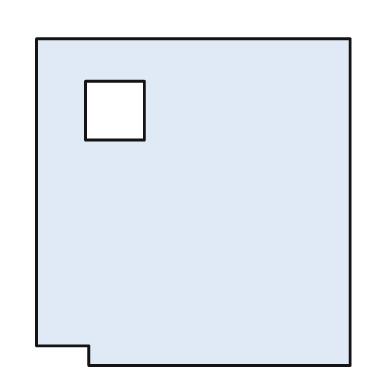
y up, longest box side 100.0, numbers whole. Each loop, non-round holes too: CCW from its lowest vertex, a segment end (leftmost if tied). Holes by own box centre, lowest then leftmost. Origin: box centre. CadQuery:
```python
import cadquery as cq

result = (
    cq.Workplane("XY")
    .moveTo(-32.0, -50.0)
    .lineTo(48.0, -50.0)
    .lineTo(48.0, 50.0)
    .lineTo(-48.0, 50.0)
    .lineTo(-48.0, -44.0)
    .lineTo(-32.0, -44.0)
    .close()
    .moveTo(-33.0, 19.0)
    .lineTo(-15.0, 19.0)
    .lineTo(-15.0, 37.0)
    .lineTo(-33.0, 37.0)
    .close()
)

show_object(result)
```